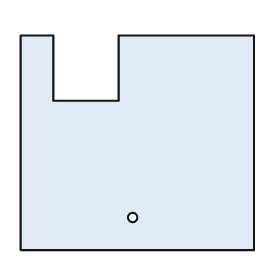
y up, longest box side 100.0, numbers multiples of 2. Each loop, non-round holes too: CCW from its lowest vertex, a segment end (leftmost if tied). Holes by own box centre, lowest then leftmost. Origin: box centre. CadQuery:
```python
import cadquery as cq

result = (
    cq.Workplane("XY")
    .moveTo(-50.0, -46.0)
    .lineTo(50.0, -46.0)
    .lineTo(50.0, 46.0)
    .lineTo(-8.0, 46.0)
    .lineTo(-8.0, 18.0)
    .lineTo(-36.0, 18.0)
    .lineTo(-36.0, 46.0)
    .lineTo(-50.0, 46.0)
    .close()
    .moveTo(-2.0, -32.0)
    .circle(2.0)
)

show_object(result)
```